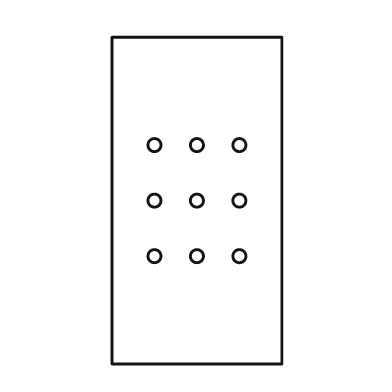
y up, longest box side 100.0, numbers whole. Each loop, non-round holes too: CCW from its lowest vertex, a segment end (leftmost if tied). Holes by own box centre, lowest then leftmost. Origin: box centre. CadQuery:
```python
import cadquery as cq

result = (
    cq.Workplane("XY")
    .moveTo(-26.0, -50.0)
    .lineTo(26.0, -50.0)
    .lineTo(26.0, 50.0)
    .lineTo(-26.0, 50.0)
    .close()
    .moveTo(-13.0, -17.0)
    .circle(2.0)
    .moveTo(0.0, -17.0)
    .circle(2.0)
    .moveTo(13.0, -17.0)
    .circle(2.0)
    .moveTo(-13.0, 0.0)
    .circle(2.0)
    .moveTo(0.0, 0.0)
    .circle(2.0)
    .moveTo(13.0, 0.0)
    .circle(2.0)
    .moveTo(-13.0, 17.0)
    .circle(2.0)
    .moveTo(0.0, 17.0)
    .circle(2.0)
    .moveTo(13.0, 17.0)
    .circle(2.0)
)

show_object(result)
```